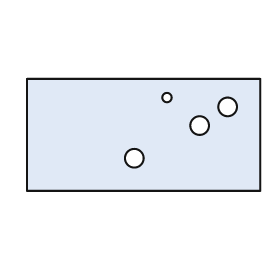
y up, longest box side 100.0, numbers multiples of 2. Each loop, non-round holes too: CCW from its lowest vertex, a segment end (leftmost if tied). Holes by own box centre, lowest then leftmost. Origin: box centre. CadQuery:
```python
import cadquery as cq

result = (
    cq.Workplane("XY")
    .moveTo(-50.0, -24.0)
    .lineTo(50.0, -24.0)
    .lineTo(50.0, 24.0)
    .lineTo(-50.0, 24.0)
    .close()
    .moveTo(-4.0, -10.0)
    .circle(4.0)
    .moveTo(24.0, 4.0)
    .circle(4.0)
    .moveTo(36.0, 12.0)
    .circle(4.0)
    .moveTo(10.0, 16.0)
    .circle(2.0)
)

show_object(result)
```